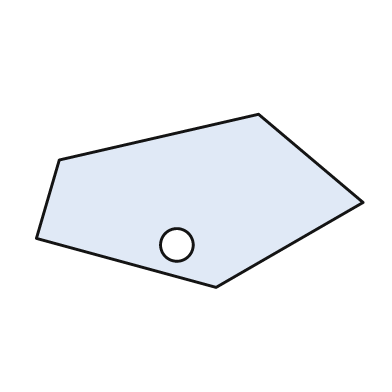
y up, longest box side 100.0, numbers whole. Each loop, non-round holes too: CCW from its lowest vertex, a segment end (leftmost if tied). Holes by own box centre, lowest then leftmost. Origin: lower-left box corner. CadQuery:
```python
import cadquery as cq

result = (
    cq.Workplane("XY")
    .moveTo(55.0, 0.0)
    .lineTo(100.0, 26.0)
    .lineTo(68.0, 53.0)
    .lineTo(7.0, 39.0)
    .lineTo(0.0, 15.0)
    .close()
    .moveTo(43.0, 13.0)
    .circle(5.0)
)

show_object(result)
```